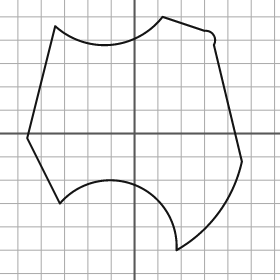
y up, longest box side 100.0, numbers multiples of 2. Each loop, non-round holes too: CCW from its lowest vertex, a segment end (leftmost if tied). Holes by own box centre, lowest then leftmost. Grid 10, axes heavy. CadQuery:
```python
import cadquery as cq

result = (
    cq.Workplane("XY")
    .moveTo(18.0, -50.0)
    .threePointArc((36.0, -34.0), (46.0, -12.0))
    .lineTo(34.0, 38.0)
    .threePointArc((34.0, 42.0), (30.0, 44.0))
    .lineTo(12.0, 50.0)
    .threePointArc((-10.0, 38.0), (-34.0, 46.0))
    .lineTo(-46.0, -2.0)
    .lineTo(-32.0, -30.0)
    .threePointArc((0.0, -22.0), (18.0, -50.0))
    .close()
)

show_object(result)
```